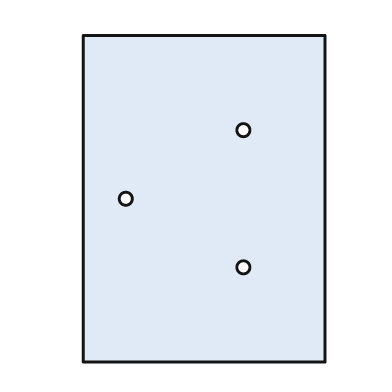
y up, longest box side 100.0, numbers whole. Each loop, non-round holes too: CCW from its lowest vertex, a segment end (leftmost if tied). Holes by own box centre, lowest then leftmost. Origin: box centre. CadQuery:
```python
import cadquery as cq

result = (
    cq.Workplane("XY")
    .moveTo(-37.0, -50.0)
    .lineTo(37.0, -50.0)
    .lineTo(37.0, 50.0)
    .lineTo(-37.0, 50.0)
    .close()
    .moveTo(12.0, -21.0)
    .circle(2.0)
    .moveTo(-24.0, 0.0)
    .circle(2.0)
    .moveTo(12.0, 21.0)
    .circle(2.0)
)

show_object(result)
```